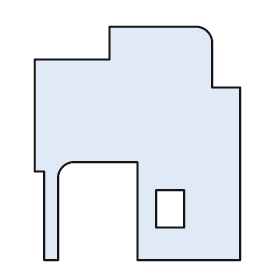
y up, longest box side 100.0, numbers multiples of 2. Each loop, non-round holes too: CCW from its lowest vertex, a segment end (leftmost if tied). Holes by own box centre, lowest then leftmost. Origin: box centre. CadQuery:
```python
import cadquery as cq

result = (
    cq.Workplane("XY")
    .moveTo(-40.0, -50.0)
    .lineTo(-34.0, -50.0)
    .lineTo(-34.0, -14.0)
    .threePointArc((-32.0, -10.0), (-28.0, -8.0))
    .lineTo(0.0, -8.0)
    .lineTo(0.0, -50.0)
    .lineTo(44.0, -50.0)
    .lineTo(44.0, 24.0)
    .lineTo(32.0, 24.0)
    .lineTo(32.0, 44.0)
    .threePointArc((30.0, 48.0), (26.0, 50.0))
    .lineTo(-12.0, 50.0)
    .lineTo(-12.0, 36.0)
    .lineTo(-44.0, 36.0)
    .lineTo(-44.0, -12.0)
    .lineTo(-40.0, -12.0)
    .close()
    .moveTo(8.0, -36.0)
    .lineTo(20.0, -36.0)
    .lineTo(20.0, -20.0)
    .lineTo(8.0, -20.0)
    .close()
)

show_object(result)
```